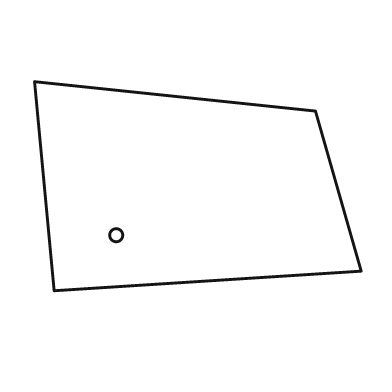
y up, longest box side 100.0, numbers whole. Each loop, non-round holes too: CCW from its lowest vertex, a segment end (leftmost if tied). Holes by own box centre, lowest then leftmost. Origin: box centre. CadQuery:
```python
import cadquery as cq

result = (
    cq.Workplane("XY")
    .moveTo(-44.0, -32.0)
    .lineTo(50.0, -26.0)
    .lineTo(36.0, 23.0)
    .lineTo(-50.0, 32.0)
    .close()
    .moveTo(-25.0, -15.0)
    .circle(2.0)
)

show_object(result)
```